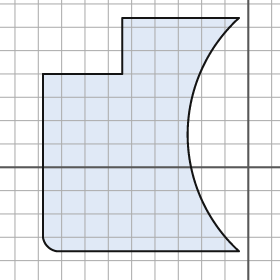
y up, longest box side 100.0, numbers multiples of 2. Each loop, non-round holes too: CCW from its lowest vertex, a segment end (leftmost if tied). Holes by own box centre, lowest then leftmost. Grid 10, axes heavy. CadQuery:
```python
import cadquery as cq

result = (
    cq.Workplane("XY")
    .moveTo(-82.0, -36.0)
    .lineTo(-4.0, -36.0)
    .threePointArc((-26.0, 14.0), (-4.0, 64.0))
    .lineTo(-54.0, 64.0)
    .lineTo(-54.0, 40.0)
    .lineTo(-88.0, 40.0)
    .lineTo(-88.0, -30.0)
    .threePointArc((-86.0, -34.0), (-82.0, -36.0))
    .close()
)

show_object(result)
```